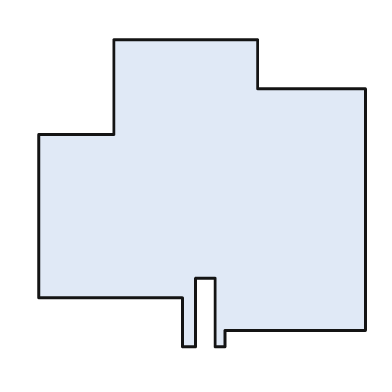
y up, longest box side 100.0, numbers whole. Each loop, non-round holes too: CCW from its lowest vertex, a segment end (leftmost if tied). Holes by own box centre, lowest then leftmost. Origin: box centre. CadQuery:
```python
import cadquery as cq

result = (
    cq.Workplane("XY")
    .moveTo(-6.0, -47.0)
    .lineTo(-2.0, -47.0)
    .lineTo(-2.0, -26.0)
    .lineTo(4.0, -26.0)
    .lineTo(4.0, -47.0)
    .lineTo(7.0, -47.0)
    .lineTo(7.0, -42.0)
    .lineTo(50.0, -42.0)
    .lineTo(50.0, 32.0)
    .lineTo(17.0, 32.0)
    .lineTo(17.0, 47.0)
    .lineTo(-27.0, 47.0)
    .lineTo(-27.0, 18.0)
    .lineTo(-50.0, 18.0)
    .lineTo(-50.0, -32.0)
    .lineTo(-6.0, -32.0)
    .close()
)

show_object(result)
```